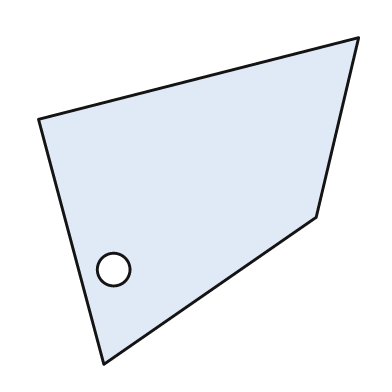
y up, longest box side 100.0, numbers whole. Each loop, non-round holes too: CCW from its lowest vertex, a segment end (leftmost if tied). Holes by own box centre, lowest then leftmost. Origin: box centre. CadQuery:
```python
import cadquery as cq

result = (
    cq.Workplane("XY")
    .moveTo(-29.0, -50.0)
    .lineTo(36.0, -5.0)
    .lineTo(49.0, 50.0)
    .lineTo(-49.0, 25.0)
    .close()
    .moveTo(-26.0, -21.0)
    .circle(5.0)
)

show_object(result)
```